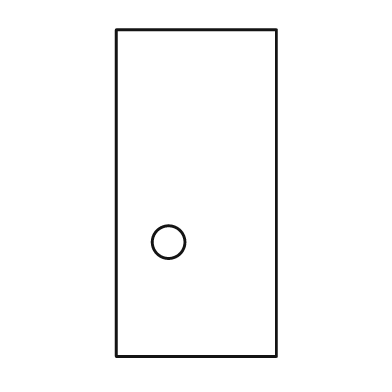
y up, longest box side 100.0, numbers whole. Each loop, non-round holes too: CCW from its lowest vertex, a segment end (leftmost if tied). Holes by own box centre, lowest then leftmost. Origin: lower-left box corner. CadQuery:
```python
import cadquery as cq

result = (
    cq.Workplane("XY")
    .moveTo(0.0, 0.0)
    .lineTo(49.0, 0.0)
    .lineTo(49.0, 100.0)
    .lineTo(0.0, 100.0)
    .close()
    .moveTo(16.0, 35.0)
    .circle(5.0)
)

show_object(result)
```